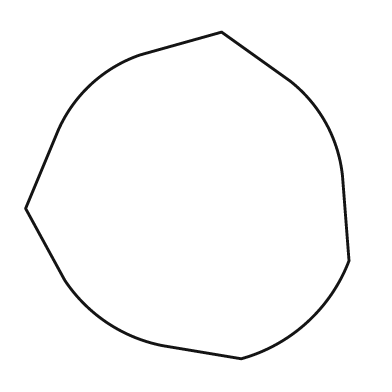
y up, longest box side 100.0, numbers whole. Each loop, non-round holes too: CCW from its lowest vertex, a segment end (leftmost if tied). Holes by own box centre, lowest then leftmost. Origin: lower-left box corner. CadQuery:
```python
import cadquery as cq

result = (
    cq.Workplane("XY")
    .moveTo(66.0, 0.0)
    .threePointArc((86.0, 11.0), (99.0, 30.0))
    .lineTo(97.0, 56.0)
    .threePointArc((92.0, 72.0), (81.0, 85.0))
    .lineTo(60.0, 100.0)
    .lineTo(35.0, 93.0)
    .threePointArc((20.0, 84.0), (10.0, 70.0))
    .lineTo(0.0, 46.0)
    .lineTo(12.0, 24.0)
    .threePointArc((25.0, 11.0), (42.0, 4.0))
    .close()
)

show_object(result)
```